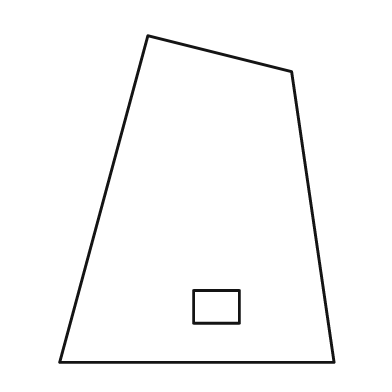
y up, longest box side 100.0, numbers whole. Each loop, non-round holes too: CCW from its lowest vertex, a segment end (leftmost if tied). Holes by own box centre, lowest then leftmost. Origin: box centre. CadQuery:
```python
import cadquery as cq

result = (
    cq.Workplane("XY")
    .moveTo(-42.0, -50.0)
    .lineTo(42.0, -50.0)
    .lineTo(29.0, 39.0)
    .lineTo(-15.0, 50.0)
    .close()
    .moveTo(-1.0, -38.0)
    .lineTo(13.0, -38.0)
    .lineTo(13.0, -28.0)
    .lineTo(-1.0, -28.0)
    .close()
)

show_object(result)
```